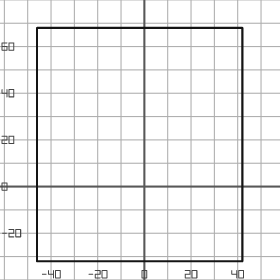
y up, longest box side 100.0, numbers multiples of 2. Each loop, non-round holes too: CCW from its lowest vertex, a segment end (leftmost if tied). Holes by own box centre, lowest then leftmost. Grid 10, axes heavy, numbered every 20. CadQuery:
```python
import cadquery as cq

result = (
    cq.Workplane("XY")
    .moveTo(-46.0, -32.0)
    .lineTo(42.0, -32.0)
    .lineTo(42.0, 68.0)
    .lineTo(-46.0, 68.0)
    .close()
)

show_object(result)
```